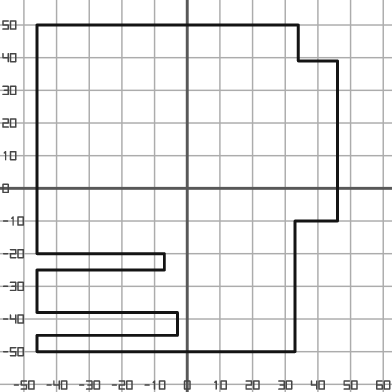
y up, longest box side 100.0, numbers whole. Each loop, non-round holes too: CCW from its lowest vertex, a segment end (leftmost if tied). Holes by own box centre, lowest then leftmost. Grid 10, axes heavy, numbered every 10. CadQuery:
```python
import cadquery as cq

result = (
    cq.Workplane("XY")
    .moveTo(-46.0, -50.0)
    .lineTo(33.0, -50.0)
    .lineTo(33.0, -10.0)
    .lineTo(46.0, -10.0)
    .lineTo(46.0, 39.0)
    .lineTo(34.0, 39.0)
    .lineTo(34.0, 50.0)
    .lineTo(-46.0, 50.0)
    .lineTo(-46.0, -20.0)
    .lineTo(-7.0, -20.0)
    .lineTo(-7.0, -25.0)
    .lineTo(-46.0, -25.0)
    .lineTo(-46.0, -38.0)
    .lineTo(-3.0, -38.0)
    .lineTo(-3.0, -45.0)
    .lineTo(-46.0, -45.0)
    .close()
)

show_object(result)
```